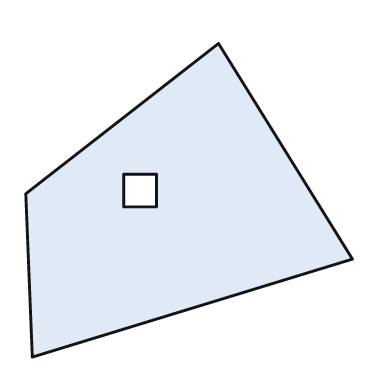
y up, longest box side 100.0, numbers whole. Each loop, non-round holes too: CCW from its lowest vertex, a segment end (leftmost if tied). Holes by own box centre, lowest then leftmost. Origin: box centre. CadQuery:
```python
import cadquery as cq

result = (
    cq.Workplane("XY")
    .moveTo(-48.0, -48.0)
    .lineTo(50.0, -18.0)
    .lineTo(9.0, 48.0)
    .lineTo(-50.0, 2.0)
    .close()
    .moveTo(-20.0, -2.0)
    .lineTo(-10.0, -2.0)
    .lineTo(-10.0, 8.0)
    .lineTo(-20.0, 8.0)
    .close()
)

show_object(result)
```